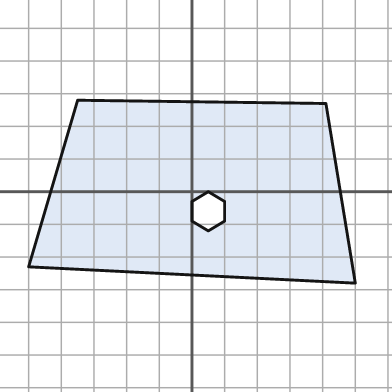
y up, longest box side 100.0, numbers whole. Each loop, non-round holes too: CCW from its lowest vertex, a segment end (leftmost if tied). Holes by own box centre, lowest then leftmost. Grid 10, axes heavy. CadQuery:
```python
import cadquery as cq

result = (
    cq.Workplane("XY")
    .moveTo(50.0, -28.0)
    .lineTo(41.0, 27.0)
    .lineTo(-35.0, 28.0)
    .lineTo(-50.0, -23.0)
    .close()
    .moveTo(5.0, -12.0)
    .lineTo(10.0, -9.0)
    .lineTo(10.0, -3.0)
    .lineTo(5.0, 0.0)
    .lineTo(0.0, -3.0)
    .lineTo(0.0, -9.0)
    .close()
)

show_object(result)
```